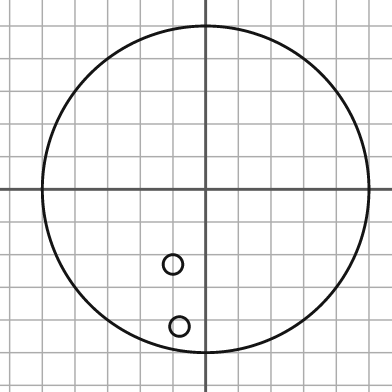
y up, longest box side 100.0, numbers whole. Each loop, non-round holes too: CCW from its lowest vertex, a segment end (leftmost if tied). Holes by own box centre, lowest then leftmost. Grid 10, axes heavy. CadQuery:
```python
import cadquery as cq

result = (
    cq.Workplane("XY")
    .moveTo(0.0, 0.0)
    .circle(50.0)
    .moveTo(-8.0, -42.0)
    .circle(3.0)
    .moveTo(-10.0, -23.0)
    .circle(3.0)
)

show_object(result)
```